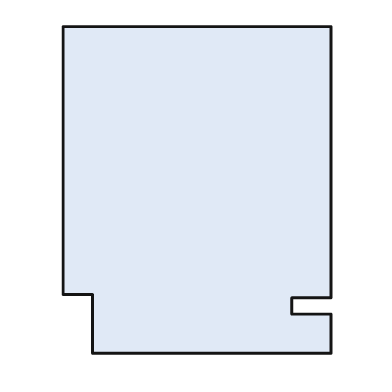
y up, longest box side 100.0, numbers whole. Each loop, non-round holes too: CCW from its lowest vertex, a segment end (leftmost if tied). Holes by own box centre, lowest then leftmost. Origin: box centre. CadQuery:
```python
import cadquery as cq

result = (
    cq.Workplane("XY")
    .moveTo(-32.0, -50.0)
    .lineTo(41.0, -50.0)
    .lineTo(41.0, -38.0)
    .lineTo(29.0, -38.0)
    .lineTo(29.0, -33.0)
    .lineTo(41.0, -33.0)
    .lineTo(41.0, 50.0)
    .lineTo(-41.0, 50.0)
    .lineTo(-41.0, -32.0)
    .lineTo(-32.0, -32.0)
    .close()
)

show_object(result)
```